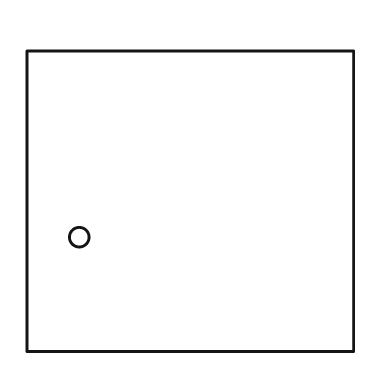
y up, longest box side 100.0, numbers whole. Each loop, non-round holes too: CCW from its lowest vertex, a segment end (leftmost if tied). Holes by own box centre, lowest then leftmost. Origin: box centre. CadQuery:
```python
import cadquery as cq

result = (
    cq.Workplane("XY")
    .moveTo(-50.0, -46.0)
    .lineTo(50.0, -46.0)
    .lineTo(50.0, 46.0)
    .lineTo(-50.0, 46.0)
    .close()
    .moveTo(-34.0, -11.0)
    .circle(3.0)
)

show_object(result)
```